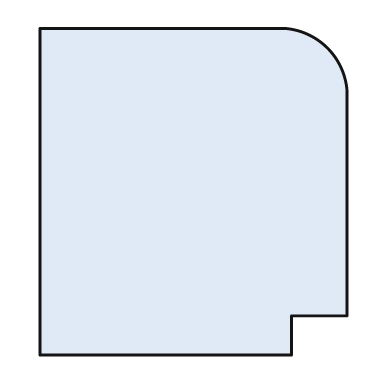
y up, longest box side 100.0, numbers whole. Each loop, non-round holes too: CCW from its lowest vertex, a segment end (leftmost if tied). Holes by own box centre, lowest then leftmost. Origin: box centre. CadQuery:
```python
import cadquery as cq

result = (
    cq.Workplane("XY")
    .moveTo(-47.0, -50.0)
    .lineTo(30.0, -50.0)
    .lineTo(30.0, -38.0)
    .lineTo(47.0, -38.0)
    .lineTo(47.0, 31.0)
    .threePointArc((41.0, 44.0), (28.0, 50.0))
    .lineTo(-47.0, 50.0)
    .close()
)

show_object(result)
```